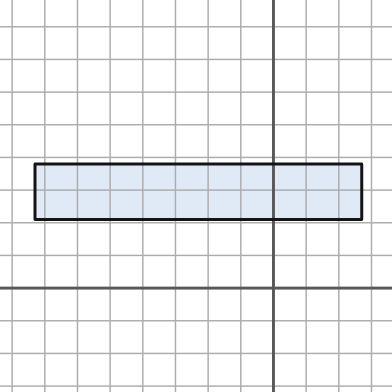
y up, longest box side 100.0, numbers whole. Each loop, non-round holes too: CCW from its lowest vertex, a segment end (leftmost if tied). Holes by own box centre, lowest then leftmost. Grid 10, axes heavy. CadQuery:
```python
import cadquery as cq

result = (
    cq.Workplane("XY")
    .moveTo(-73.0, 21.0)
    .lineTo(27.0, 21.0)
    .lineTo(27.0, 38.0)
    .lineTo(-73.0, 38.0)
    .close()
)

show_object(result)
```